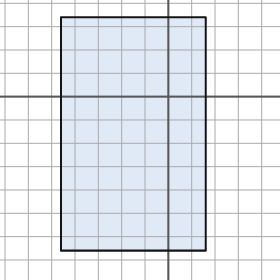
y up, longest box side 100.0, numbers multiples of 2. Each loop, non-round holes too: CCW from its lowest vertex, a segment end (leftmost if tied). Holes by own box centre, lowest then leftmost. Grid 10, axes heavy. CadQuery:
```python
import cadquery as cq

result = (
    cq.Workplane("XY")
    .moveTo(-46.0, -66.0)
    .lineTo(16.0, -66.0)
    .lineTo(16.0, 34.0)
    .lineTo(-46.0, 34.0)
    .close()
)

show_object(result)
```